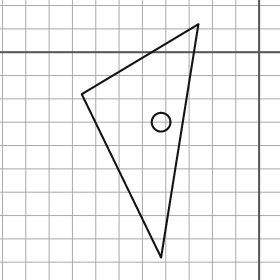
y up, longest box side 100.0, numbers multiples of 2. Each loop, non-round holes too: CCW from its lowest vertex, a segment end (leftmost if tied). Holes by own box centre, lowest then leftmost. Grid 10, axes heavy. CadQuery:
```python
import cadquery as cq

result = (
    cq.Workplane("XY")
    .moveTo(-42.0, -88.0)
    .lineTo(-26.0, 12.0)
    .lineTo(-76.0, -18.0)
    .close()
    .moveTo(-42.0, -30.0)
    .circle(4.0)
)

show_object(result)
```